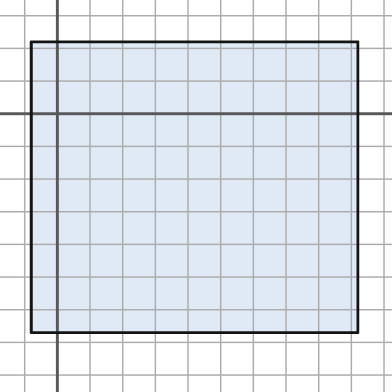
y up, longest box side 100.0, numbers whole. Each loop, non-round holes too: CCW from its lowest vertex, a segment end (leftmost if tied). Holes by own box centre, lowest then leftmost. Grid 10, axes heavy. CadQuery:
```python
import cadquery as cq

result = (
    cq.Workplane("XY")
    .moveTo(-8.0, -67.0)
    .lineTo(92.0, -67.0)
    .lineTo(92.0, 22.0)
    .lineTo(-8.0, 22.0)
    .close()
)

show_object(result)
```